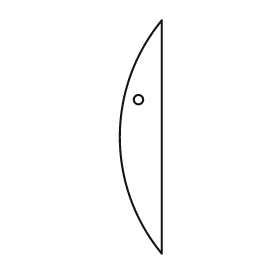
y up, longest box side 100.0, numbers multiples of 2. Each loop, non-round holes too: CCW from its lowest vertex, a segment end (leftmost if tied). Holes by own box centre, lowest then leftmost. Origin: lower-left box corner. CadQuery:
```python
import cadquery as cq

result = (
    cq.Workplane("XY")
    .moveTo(18.0, 0.0)
    .lineTo(18.0, 100.0)
    .threePointArc((0.0, 50.0), (18.0, 0.0))
    .close()
    .moveTo(8.0, 66.0)
    .circle(2.0)
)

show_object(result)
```